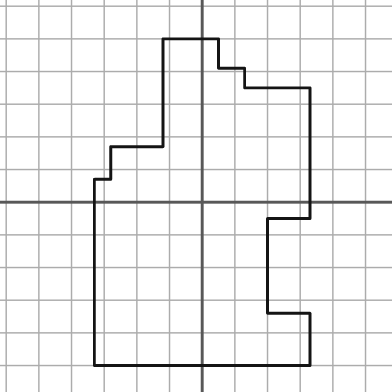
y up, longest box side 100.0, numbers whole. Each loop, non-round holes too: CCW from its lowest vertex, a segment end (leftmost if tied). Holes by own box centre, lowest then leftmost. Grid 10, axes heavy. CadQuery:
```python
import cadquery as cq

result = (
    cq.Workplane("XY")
    .moveTo(-33.0, -50.0)
    .lineTo(33.0, -50.0)
    .lineTo(33.0, -34.0)
    .lineTo(20.0, -34.0)
    .lineTo(20.0, -5.0)
    .lineTo(33.0, -5.0)
    .lineTo(33.0, 35.0)
    .lineTo(13.0, 35.0)
    .lineTo(13.0, 41.0)
    .lineTo(5.0, 41.0)
    .lineTo(5.0, 50.0)
    .lineTo(-12.0, 50.0)
    .lineTo(-12.0, 17.0)
    .lineTo(-28.0, 17.0)
    .lineTo(-28.0, 7.0)
    .lineTo(-33.0, 7.0)
    .close()
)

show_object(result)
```